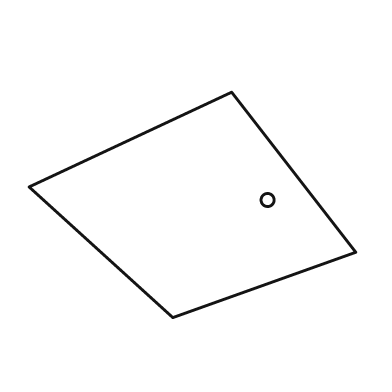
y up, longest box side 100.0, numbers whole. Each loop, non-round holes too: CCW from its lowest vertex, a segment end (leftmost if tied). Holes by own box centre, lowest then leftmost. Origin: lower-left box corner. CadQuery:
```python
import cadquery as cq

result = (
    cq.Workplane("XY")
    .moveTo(44.0, 0.0)
    .lineTo(100.0, 20.0)
    .lineTo(62.0, 69.0)
    .lineTo(0.0, 40.0)
    .close()
    .moveTo(73.0, 36.0)
    .circle(2.0)
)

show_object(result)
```